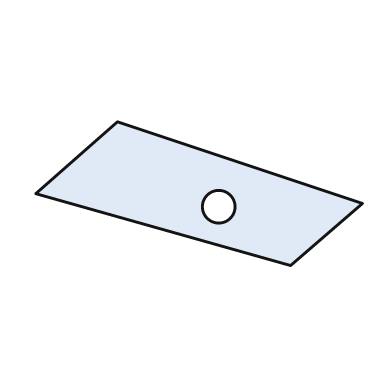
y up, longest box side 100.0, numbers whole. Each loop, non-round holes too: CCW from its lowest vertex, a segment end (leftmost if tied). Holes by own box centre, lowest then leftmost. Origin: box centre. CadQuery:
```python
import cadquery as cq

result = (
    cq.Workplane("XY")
    .moveTo(28.0, -22.0)
    .lineTo(50.0, -3.0)
    .lineTo(-25.0, 22.0)
    .lineTo(-50.0, 0.0)
    .close()
    .moveTo(6.0, -4.0)
    .circle(5.0)
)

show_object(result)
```